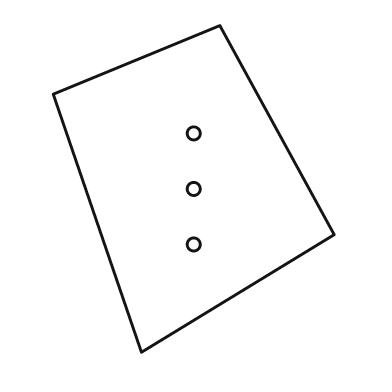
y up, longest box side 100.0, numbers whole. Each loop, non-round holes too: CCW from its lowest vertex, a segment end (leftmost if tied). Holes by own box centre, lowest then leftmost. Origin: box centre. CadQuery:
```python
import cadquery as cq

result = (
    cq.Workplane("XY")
    .moveTo(-16.0, -50.0)
    .lineTo(43.0, -14.0)
    .lineTo(8.0, 50.0)
    .lineTo(-43.0, 29.0)
    .close()
    .moveTo(0.0, -17.0)
    .circle(2.0)
    .moveTo(0.0, 0.0)
    .circle(2.0)
    .moveTo(0.0, 17.0)
    .circle(2.0)
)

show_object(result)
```